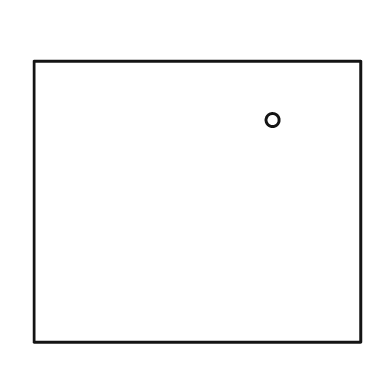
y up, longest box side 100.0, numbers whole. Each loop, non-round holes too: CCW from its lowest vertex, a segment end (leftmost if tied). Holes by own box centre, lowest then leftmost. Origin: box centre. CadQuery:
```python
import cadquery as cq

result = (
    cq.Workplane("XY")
    .moveTo(-50.0, -43.0)
    .lineTo(50.0, -43.0)
    .lineTo(50.0, 43.0)
    .lineTo(-50.0, 43.0)
    .close()
    .moveTo(23.0, 25.0)
    .circle(2.0)
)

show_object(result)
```